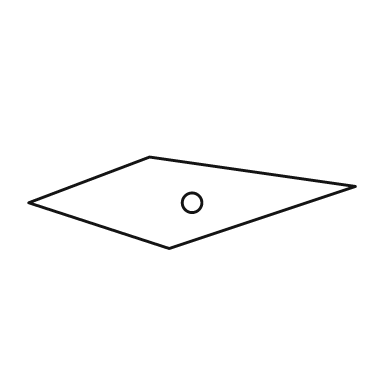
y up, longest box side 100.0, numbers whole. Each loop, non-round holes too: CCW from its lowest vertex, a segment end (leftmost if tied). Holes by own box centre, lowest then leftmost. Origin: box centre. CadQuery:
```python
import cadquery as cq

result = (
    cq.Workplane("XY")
    .moveTo(-7.0, -14.0)
    .lineTo(50.0, 5.0)
    .lineTo(-13.0, 14.0)
    .lineTo(-50.0, 0.0)
    .close()
    .moveTo(0.0, 0.0)
    .circle(3.0)
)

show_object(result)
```